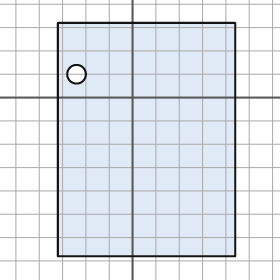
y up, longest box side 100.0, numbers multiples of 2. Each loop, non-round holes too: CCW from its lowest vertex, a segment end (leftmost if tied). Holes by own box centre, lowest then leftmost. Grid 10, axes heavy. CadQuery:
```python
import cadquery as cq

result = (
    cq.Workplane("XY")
    .moveTo(-32.0, -68.0)
    .lineTo(44.0, -68.0)
    .lineTo(44.0, 32.0)
    .lineTo(-32.0, 32.0)
    .close()
    .moveTo(-24.0, 10.0)
    .circle(4.0)
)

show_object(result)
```